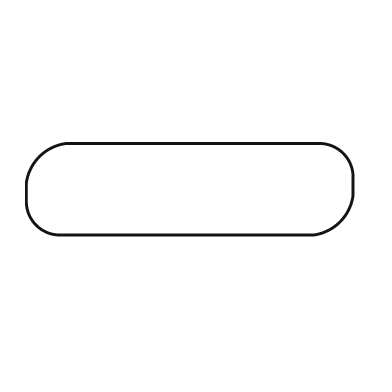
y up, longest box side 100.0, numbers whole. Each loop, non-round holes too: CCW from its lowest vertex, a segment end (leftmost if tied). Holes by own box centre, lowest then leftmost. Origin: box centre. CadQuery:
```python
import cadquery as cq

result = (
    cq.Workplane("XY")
    .moveTo(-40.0, -14.0)
    .lineTo(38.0, -14.0)
    .threePointArc((46.0, -10.0), (50.0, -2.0))
    .lineTo(50.0, 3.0)
    .threePointArc((47.0, 11.0), (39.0, 14.0))
    .lineTo(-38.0, 14.0)
    .threePointArc((-46.0, 10.0), (-50.0, 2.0))
    .lineTo(-50.0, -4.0)
    .threePointArc((-47.0, -11.0), (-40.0, -14.0))
    .close()
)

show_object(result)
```